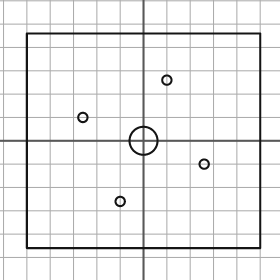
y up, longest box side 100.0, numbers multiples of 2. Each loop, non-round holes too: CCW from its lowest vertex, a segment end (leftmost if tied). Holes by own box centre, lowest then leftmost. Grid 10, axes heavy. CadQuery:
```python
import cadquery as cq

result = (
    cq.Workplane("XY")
    .moveTo(-50.0, -46.0)
    .lineTo(50.0, -46.0)
    .lineTo(50.0, 46.0)
    .lineTo(-50.0, 46.0)
    .close()
    .moveTo(-10.0, -26.0)
    .circle(2.0)
    .moveTo(26.0, -10.0)
    .circle(2.0)
    .moveTo(0.0, 0.0)
    .circle(6.0)
    .moveTo(-26.0, 10.0)
    .circle(2.0)
    .moveTo(10.0, 26.0)
    .circle(2.0)
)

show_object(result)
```